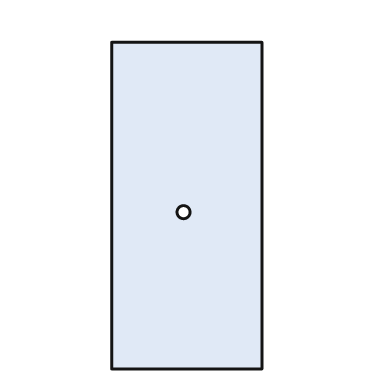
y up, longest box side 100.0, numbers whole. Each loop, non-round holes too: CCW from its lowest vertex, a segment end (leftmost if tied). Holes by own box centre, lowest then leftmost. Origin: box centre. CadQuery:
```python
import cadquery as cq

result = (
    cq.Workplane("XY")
    .moveTo(-23.0, -50.0)
    .lineTo(23.0, -50.0)
    .lineTo(23.0, 50.0)
    .lineTo(-23.0, 50.0)
    .close()
    .moveTo(-1.0, -2.0)
    .circle(2.0)
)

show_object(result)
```